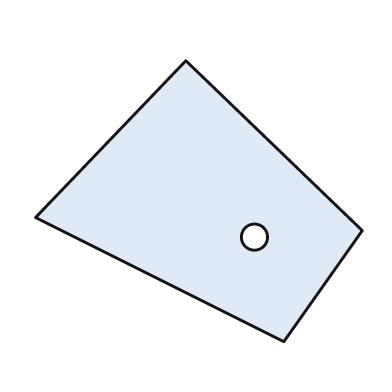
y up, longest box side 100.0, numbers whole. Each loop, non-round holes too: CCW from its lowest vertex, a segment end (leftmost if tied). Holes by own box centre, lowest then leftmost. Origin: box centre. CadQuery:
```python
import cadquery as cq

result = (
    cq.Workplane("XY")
    .moveTo(26.0, -43.0)
    .lineTo(50.0, -9.0)
    .lineTo(-4.0, 43.0)
    .lineTo(-50.0, -5.0)
    .close()
    .moveTo(17.0, -11.0)
    .circle(4.0)
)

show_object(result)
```